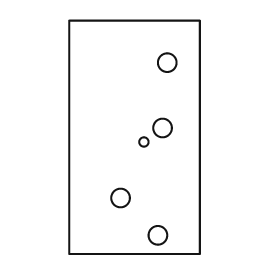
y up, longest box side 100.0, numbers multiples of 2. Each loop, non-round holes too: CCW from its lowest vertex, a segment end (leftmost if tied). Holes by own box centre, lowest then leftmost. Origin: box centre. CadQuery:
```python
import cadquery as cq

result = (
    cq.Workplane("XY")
    .moveTo(-28.0, -50.0)
    .lineTo(28.0, -50.0)
    .lineTo(28.0, 50.0)
    .lineTo(-28.0, 50.0)
    .close()
    .moveTo(10.0, -42.0)
    .circle(4.0)
    .moveTo(-6.0, -26.0)
    .circle(4.0)
    .moveTo(4.0, -2.0)
    .circle(2.0)
    .moveTo(12.0, 4.0)
    .circle(4.0)
    .moveTo(14.0, 32.0)
    .circle(4.0)
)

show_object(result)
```